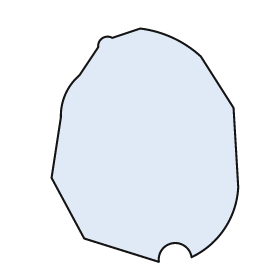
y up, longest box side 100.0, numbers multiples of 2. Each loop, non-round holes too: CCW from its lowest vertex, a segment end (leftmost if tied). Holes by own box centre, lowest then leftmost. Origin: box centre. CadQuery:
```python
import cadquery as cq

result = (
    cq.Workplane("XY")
    .moveTo(6.0, -50.0)
    .threePointArc((12.0, -42.0), (20.0, -48.0))
    .threePointArc((34.0, -36.0), (40.0, -18.0))
    .lineTo(38.0, 16.0)
    .lineTo(24.0, 38.0)
    .threePointArc((12.0, 46.0), (-2.0, 50.0))
    .lineTo(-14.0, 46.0)
    .threePointArc((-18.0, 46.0), (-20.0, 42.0))
    .lineTo(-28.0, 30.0)
    .threePointArc((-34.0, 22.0), (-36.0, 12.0))
    .lineTo(-40.0, -14.0)
    .lineTo(-26.0, -40.0)
    .close()
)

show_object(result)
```